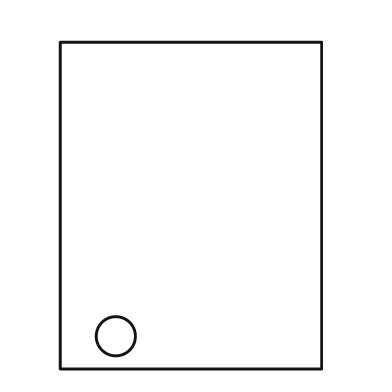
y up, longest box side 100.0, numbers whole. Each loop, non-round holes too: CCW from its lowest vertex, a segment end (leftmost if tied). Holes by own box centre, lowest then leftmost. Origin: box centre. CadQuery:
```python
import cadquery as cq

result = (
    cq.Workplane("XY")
    .moveTo(-40.0, -50.0)
    .lineTo(40.0, -50.0)
    .lineTo(40.0, 50.0)
    .lineTo(-40.0, 50.0)
    .close()
    .moveTo(-23.0, -40.0)
    .circle(6.0)
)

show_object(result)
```